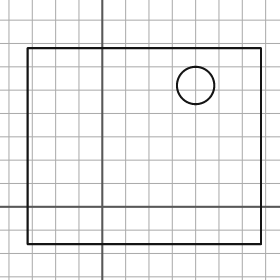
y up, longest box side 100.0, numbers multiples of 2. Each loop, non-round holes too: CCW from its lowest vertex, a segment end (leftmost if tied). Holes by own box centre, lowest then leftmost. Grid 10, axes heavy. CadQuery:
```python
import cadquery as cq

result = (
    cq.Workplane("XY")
    .moveTo(-32.0, -16.0)
    .lineTo(68.0, -16.0)
    .lineTo(68.0, 68.0)
    .lineTo(-32.0, 68.0)
    .close()
    .moveTo(40.0, 52.0)
    .circle(8.0)
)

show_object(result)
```